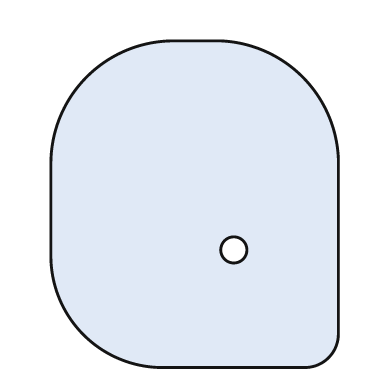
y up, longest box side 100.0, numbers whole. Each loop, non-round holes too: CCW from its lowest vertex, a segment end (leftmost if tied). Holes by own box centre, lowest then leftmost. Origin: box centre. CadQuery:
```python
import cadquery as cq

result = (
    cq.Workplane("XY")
    .moveTo(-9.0, -50.0)
    .lineTo(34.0, -50.0)
    .threePointArc((41.0, -47.0), (44.0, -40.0))
    .lineTo(44.0, 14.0)
    .threePointArc((33.0, 39.0), (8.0, 50.0))
    .lineTo(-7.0, 50.0)
    .threePointArc((-33.0, 39.0), (-44.0, 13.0))
    .lineTo(-44.0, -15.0)
    .threePointArc((-34.0, -40.0), (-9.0, -50.0))
    .close()
    .moveTo(12.0, -14.0)
    .circle(4.0)
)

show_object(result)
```